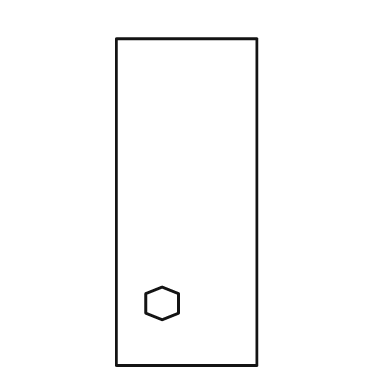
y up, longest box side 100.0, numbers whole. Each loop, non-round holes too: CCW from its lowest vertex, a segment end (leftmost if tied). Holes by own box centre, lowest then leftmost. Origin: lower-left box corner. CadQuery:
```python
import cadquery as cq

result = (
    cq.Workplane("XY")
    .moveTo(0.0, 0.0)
    .lineTo(43.0, 0.0)
    .lineTo(43.0, 100.0)
    .lineTo(0.0, 100.0)
    .close()
    .moveTo(14.0, 14.0)
    .lineTo(19.0, 16.0)
    .lineTo(19.0, 22.0)
    .lineTo(14.0, 24.0)
    .lineTo(9.0, 22.0)
    .lineTo(9.0, 16.0)
    .close()
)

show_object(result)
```